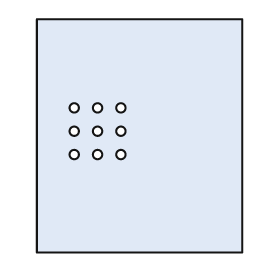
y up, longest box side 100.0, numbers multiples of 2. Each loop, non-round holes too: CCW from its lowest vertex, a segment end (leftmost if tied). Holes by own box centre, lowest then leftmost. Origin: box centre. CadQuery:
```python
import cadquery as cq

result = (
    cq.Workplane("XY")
    .moveTo(-44.0, -50.0)
    .lineTo(44.0, -50.0)
    .lineTo(44.0, 50.0)
    .lineTo(-44.0, 50.0)
    .close()
    .moveTo(-28.0, -8.0)
    .circle(2.0)
    .moveTo(-18.0, -8.0)
    .circle(2.0)
    .moveTo(-8.0, -8.0)
    .circle(2.0)
    .moveTo(-28.0, 2.0)
    .circle(2.0)
    .moveTo(-18.0, 2.0)
    .circle(2.0)
    .moveTo(-8.0, 2.0)
    .circle(2.0)
    .moveTo(-28.0, 12.0)
    .circle(2.0)
    .moveTo(-18.0, 12.0)
    .circle(2.0)
    .moveTo(-8.0, 12.0)
    .circle(2.0)
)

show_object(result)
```